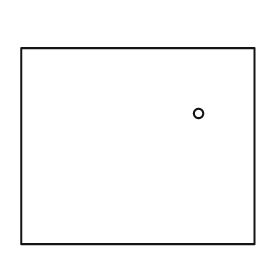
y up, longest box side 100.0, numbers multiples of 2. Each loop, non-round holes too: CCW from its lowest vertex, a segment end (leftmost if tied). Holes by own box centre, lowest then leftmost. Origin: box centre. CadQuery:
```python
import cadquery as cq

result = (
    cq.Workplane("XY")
    .moveTo(-50.0, -42.0)
    .lineTo(50.0, -42.0)
    .lineTo(50.0, 42.0)
    .lineTo(-50.0, 42.0)
    .close()
    .moveTo(26.0, 14.0)
    .circle(2.0)
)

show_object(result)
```